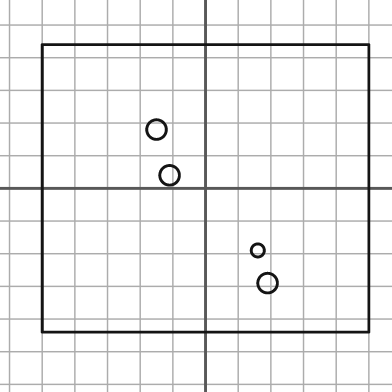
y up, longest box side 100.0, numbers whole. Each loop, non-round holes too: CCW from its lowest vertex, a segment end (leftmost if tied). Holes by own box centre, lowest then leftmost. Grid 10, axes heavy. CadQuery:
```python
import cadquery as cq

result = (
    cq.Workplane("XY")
    .moveTo(-50.0, -44.0)
    .lineTo(50.0, -44.0)
    .lineTo(50.0, 44.0)
    .lineTo(-50.0, 44.0)
    .close()
    .moveTo(19.0, -29.0)
    .circle(3.0)
    .moveTo(16.0, -19.0)
    .circle(2.0)
    .moveTo(-11.0, 4.0)
    .circle(3.0)
    .moveTo(-15.0, 18.0)
    .circle(3.0)
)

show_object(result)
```